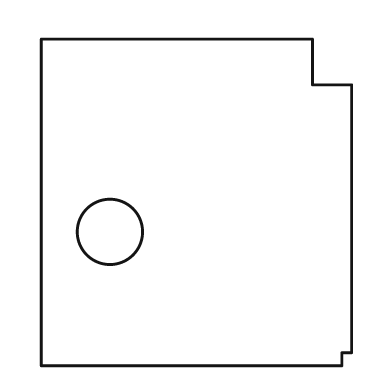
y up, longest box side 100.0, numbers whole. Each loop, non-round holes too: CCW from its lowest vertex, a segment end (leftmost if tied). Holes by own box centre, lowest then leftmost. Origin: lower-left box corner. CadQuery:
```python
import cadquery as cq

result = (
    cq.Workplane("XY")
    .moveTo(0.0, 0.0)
    .lineTo(92.0, 0.0)
    .lineTo(92.0, 4.0)
    .lineTo(95.0, 4.0)
    .lineTo(95.0, 86.0)
    .lineTo(83.0, 86.0)
    .lineTo(83.0, 100.0)
    .lineTo(0.0, 100.0)
    .close()
    .moveTo(21.0, 41.0)
    .circle(10.0)
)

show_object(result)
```